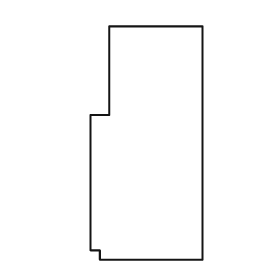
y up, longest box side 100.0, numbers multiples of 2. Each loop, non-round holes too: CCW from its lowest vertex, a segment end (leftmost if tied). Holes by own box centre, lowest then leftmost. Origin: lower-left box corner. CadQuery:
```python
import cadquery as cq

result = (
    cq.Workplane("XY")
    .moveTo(4.0, 0.0)
    .lineTo(48.0, 0.0)
    .lineTo(48.0, 100.0)
    .lineTo(8.0, 100.0)
    .lineTo(8.0, 62.0)
    .lineTo(0.0, 62.0)
    .lineTo(0.0, 4.0)
    .lineTo(4.0, 4.0)
    .close()
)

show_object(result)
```